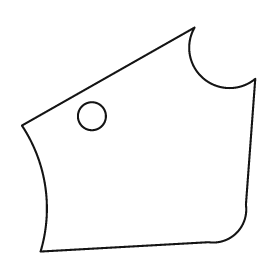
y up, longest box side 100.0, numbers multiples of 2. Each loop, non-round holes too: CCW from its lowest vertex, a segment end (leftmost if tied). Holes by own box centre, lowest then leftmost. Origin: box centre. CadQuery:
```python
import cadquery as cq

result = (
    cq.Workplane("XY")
    .moveTo(-42.0, -48.0)
    .lineTo(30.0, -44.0)
    .threePointArc((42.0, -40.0), (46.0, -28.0))
    .lineTo(50.0, 26.0)
    .threePointArc((28.0, 26.0), (24.0, 48.0))
    .lineTo(-50.0, 6.0)
    .threePointArc((-40.0, -20.0), (-42.0, -48.0))
    .close()
    .moveTo(-20.0, 10.0)
    .circle(6.0)
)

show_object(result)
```